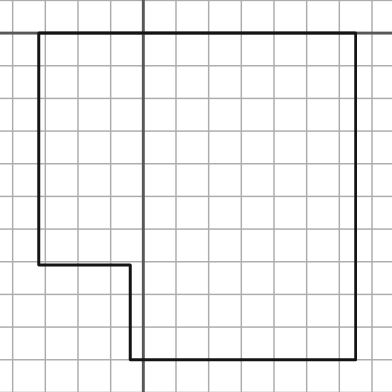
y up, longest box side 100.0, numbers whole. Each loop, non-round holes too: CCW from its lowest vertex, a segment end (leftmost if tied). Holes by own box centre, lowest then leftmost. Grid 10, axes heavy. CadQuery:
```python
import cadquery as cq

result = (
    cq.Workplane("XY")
    .moveTo(-4.0, -100.0)
    .lineTo(65.0, -100.0)
    .lineTo(65.0, 0.0)
    .lineTo(-32.0, 0.0)
    .lineTo(-32.0, -71.0)
    .lineTo(-4.0, -71.0)
    .close()
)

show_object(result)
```